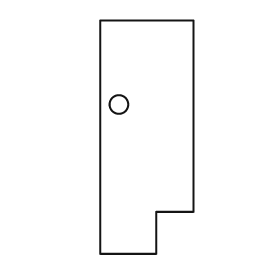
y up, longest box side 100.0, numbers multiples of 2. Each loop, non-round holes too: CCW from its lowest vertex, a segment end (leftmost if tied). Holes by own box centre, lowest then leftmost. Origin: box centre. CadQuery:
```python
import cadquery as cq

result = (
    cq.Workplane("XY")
    .moveTo(-20.0, -50.0)
    .lineTo(4.0, -50.0)
    .lineTo(4.0, -32.0)
    .lineTo(20.0, -32.0)
    .lineTo(20.0, 50.0)
    .lineTo(-20.0, 50.0)
    .close()
    .moveTo(-12.0, 14.0)
    .circle(4.0)
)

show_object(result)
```